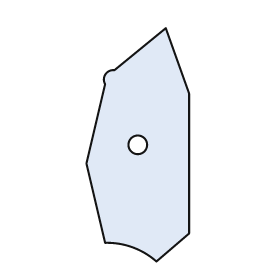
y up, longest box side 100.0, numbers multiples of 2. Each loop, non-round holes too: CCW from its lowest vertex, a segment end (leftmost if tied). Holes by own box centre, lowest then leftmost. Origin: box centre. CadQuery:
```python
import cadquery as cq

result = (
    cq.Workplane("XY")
    .moveTo(8.0, -50.0)
    .lineTo(22.0, -38.0)
    .lineTo(22.0, 22.0)
    .lineTo(12.0, 50.0)
    .lineTo(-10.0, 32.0)
    .threePointArc((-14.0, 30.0), (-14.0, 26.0))
    .lineTo(-22.0, -8.0)
    .lineTo(-14.0, -42.0)
    .threePointArc((-2.0, -44.0), (8.0, -50.0))
    .close()
    .moveTo(0.0, 0.0)
    .circle(4.0)
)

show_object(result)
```